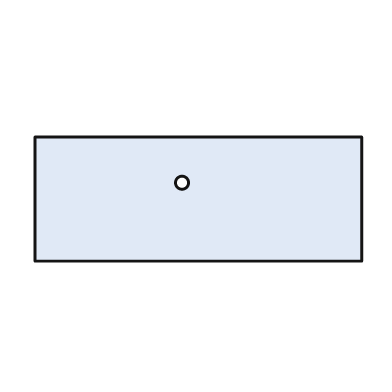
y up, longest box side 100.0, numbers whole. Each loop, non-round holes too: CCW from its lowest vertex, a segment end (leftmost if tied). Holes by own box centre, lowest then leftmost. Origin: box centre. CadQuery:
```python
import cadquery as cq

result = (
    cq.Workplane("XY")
    .moveTo(-50.0, -19.0)
    .lineTo(50.0, -19.0)
    .lineTo(50.0, 19.0)
    .lineTo(-50.0, 19.0)
    .close()
    .moveTo(-5.0, 5.0)
    .circle(2.0)
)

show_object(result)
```